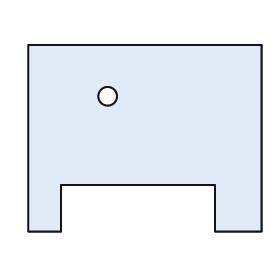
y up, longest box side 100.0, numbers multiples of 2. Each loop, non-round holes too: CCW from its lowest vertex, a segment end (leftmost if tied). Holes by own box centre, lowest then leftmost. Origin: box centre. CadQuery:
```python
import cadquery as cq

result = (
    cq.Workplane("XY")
    .moveTo(-50.0, -40.0)
    .lineTo(-36.0, -40.0)
    .lineTo(-36.0, -20.0)
    .lineTo(30.0, -20.0)
    .lineTo(30.0, -40.0)
    .lineTo(50.0, -40.0)
    .lineTo(50.0, 40.0)
    .lineTo(-50.0, 40.0)
    .close()
    .moveTo(-16.0, 18.0)
    .circle(4.0)
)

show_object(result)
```